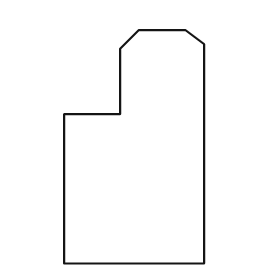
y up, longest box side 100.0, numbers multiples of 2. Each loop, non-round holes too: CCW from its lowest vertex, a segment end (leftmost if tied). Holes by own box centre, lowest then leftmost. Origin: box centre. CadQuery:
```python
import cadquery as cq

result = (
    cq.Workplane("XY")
    .moveTo(-30.0, -50.0)
    .lineTo(30.0, -50.0)
    .lineTo(30.0, 44.0)
    .lineTo(22.0, 50.0)
    .lineTo(2.0, 50.0)
    .lineTo(-6.0, 42.0)
    .lineTo(-6.0, 14.0)
    .lineTo(-30.0, 14.0)
    .close()
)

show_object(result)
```